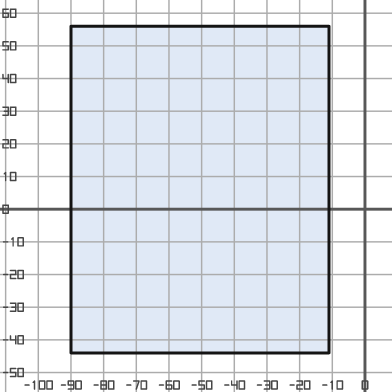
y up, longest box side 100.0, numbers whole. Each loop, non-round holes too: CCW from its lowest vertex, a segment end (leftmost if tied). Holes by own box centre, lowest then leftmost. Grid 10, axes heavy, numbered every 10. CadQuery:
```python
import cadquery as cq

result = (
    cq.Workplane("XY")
    .moveTo(-90.0, -44.0)
    .lineTo(-11.0, -44.0)
    .lineTo(-11.0, 56.0)
    .lineTo(-90.0, 56.0)
    .close()
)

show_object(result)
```